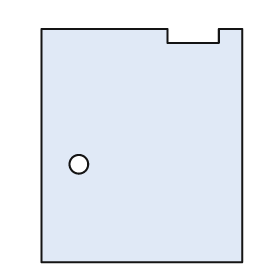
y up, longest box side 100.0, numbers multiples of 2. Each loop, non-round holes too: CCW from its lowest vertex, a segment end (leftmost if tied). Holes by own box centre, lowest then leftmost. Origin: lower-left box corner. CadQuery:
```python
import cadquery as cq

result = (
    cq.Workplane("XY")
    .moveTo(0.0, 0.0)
    .lineTo(86.0, 0.0)
    .lineTo(86.0, 100.0)
    .lineTo(76.0, 100.0)
    .lineTo(76.0, 94.0)
    .lineTo(54.0, 94.0)
    .lineTo(54.0, 100.0)
    .lineTo(0.0, 100.0)
    .close()
    .moveTo(16.0, 42.0)
    .circle(4.0)
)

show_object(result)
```